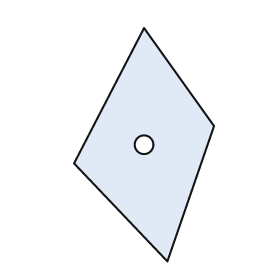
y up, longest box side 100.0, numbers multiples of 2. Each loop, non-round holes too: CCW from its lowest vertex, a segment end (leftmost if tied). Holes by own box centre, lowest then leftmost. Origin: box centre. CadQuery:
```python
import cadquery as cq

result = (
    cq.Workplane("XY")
    .moveTo(10.0, -50.0)
    .lineTo(30.0, 8.0)
    .lineTo(0.0, 50.0)
    .lineTo(-30.0, -8.0)
    .close()
    .moveTo(0.0, 0.0)
    .circle(4.0)
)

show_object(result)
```